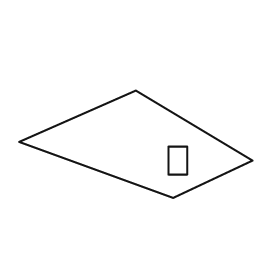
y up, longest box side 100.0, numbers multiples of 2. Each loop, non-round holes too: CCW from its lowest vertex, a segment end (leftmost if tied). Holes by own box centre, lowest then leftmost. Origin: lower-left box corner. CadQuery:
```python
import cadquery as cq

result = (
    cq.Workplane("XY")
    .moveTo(66.0, 0.0)
    .lineTo(100.0, 16.0)
    .lineTo(50.0, 46.0)
    .lineTo(0.0, 24.0)
    .close()
    .moveTo(64.0, 10.0)
    .lineTo(72.0, 10.0)
    .lineTo(72.0, 22.0)
    .lineTo(64.0, 22.0)
    .close()
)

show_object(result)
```